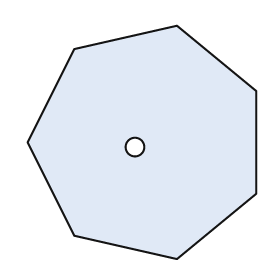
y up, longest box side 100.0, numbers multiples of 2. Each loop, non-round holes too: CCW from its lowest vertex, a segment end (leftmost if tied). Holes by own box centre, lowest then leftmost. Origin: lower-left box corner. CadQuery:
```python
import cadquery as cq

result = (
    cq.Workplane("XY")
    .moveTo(64.0, 0.0)
    .lineTo(98.0, 28.0)
    .lineTo(98.0, 72.0)
    .lineTo(64.0, 100.0)
    .lineTo(20.0, 90.0)
    .lineTo(0.0, 50.0)
    .lineTo(20.0, 10.0)
    .close()
    .moveTo(46.0, 48.0)
    .circle(4.0)
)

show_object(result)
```